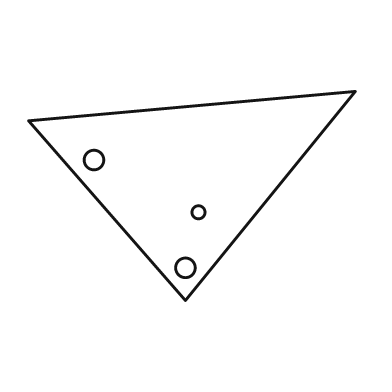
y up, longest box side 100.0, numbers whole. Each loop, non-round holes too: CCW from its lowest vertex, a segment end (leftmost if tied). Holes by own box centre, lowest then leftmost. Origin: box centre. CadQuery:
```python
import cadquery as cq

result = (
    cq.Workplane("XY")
    .moveTo(-2.0, -32.0)
    .lineTo(50.0, 32.0)
    .lineTo(-50.0, 23.0)
    .close()
    .moveTo(-2.0, -22.0)
    .circle(3.0)
    .moveTo(2.0, -5.0)
    .circle(2.0)
    .moveTo(-30.0, 11.0)
    .circle(3.0)
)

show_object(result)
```